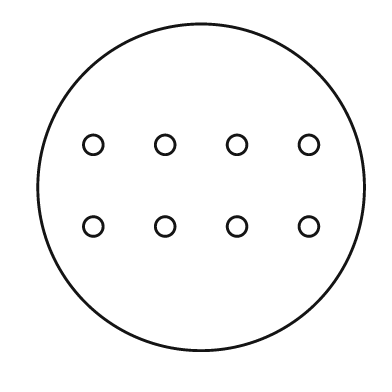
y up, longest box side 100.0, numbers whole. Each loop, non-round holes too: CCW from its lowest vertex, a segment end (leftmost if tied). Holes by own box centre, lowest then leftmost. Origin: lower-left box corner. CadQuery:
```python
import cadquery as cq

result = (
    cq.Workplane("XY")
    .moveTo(50.0, 50.0)
    .circle(50.0)
    .moveTo(17.0, 38.0)
    .circle(3.0)
    .moveTo(39.0, 38.0)
    .circle(3.0)
    .moveTo(61.0, 38.0)
    .circle(3.0)
    .moveTo(83.0, 38.0)
    .circle(3.0)
    .moveTo(17.0, 63.0)
    .circle(3.0)
    .moveTo(39.0, 63.0)
    .circle(3.0)
    .moveTo(61.0, 63.0)
    .circle(3.0)
    .moveTo(83.0, 63.0)
    .circle(3.0)
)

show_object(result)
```